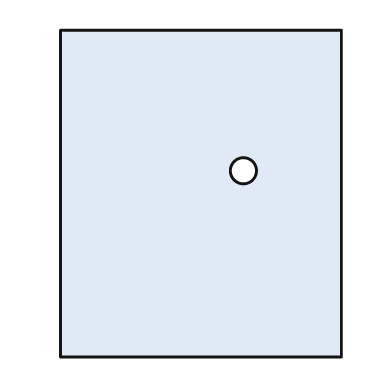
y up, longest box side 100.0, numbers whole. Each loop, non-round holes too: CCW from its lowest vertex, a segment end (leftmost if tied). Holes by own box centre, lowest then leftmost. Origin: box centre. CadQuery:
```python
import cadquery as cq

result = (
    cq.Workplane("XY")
    .moveTo(-43.0, -50.0)
    .lineTo(43.0, -50.0)
    .lineTo(43.0, 50.0)
    .lineTo(-43.0, 50.0)
    .close()
    .moveTo(13.0, 7.0)
    .circle(4.0)
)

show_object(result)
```